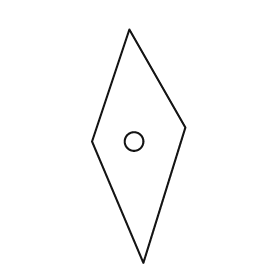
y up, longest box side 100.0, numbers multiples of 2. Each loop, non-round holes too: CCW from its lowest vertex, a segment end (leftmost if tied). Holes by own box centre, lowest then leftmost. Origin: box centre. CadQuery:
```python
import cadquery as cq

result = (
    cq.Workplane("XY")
    .moveTo(2.0, -50.0)
    .lineTo(20.0, 8.0)
    .lineTo(-4.0, 50.0)
    .lineTo(-20.0, 2.0)
    .close()
    .moveTo(-2.0, 2.0)
    .circle(4.0)
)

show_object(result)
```